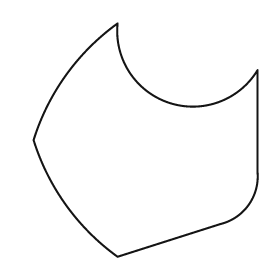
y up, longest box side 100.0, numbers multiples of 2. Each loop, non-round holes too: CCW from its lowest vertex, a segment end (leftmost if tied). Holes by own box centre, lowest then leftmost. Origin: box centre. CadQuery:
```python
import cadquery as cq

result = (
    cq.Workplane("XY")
    .moveTo(-12.0, -50.0)
    .lineTo(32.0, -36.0)
    .threePointArc((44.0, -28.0), (48.0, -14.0))
    .lineTo(48.0, 30.0)
    .threePointArc((10.0, 16.0), (-12.0, 50.0))
    .threePointArc((-34.0, 28.0), (-48.0, 0.0))
    .threePointArc((-34.0, -28.0), (-12.0, -50.0))
    .close()
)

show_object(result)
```